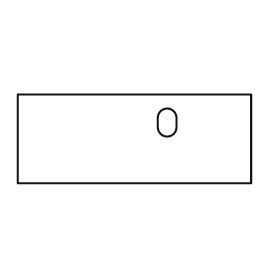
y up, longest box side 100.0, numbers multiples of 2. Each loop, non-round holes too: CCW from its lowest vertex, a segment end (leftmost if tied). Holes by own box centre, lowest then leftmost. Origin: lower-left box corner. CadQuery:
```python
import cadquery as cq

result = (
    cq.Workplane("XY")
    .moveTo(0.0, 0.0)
    .lineTo(100.0, 0.0)
    .lineTo(100.0, 38.0)
    .lineTo(0.0, 38.0)
    .close()
    .moveTo(60.0, 24.0)
    .threePointArc((64.0, 20.0), (68.0, 24.0))
    .lineTo(68.0, 28.0)
    .threePointArc((64.0, 32.0), (60.0, 28.0))
    .close()
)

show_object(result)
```